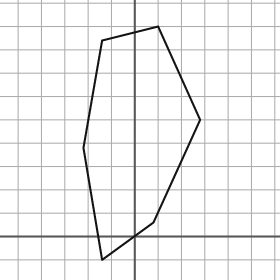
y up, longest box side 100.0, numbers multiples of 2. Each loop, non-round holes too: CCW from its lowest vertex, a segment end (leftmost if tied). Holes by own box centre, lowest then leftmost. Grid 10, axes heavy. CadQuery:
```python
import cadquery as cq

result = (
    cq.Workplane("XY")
    .moveTo(-14.0, -10.0)
    .lineTo(8.0, 6.0)
    .lineTo(28.0, 50.0)
    .lineTo(10.0, 90.0)
    .lineTo(-14.0, 84.0)
    .lineTo(-22.0, 38.0)
    .close()
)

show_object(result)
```